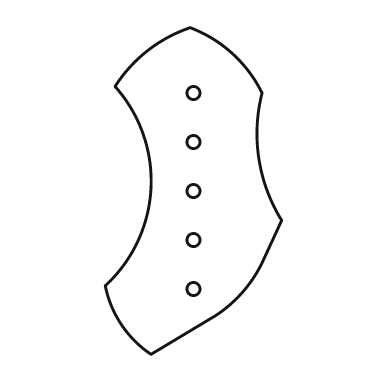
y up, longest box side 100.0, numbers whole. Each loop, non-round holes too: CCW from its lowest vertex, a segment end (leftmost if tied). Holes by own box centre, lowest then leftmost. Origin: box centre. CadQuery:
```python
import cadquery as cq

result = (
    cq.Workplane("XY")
    .moveTo(-13.0, -50.0)
    .lineTo(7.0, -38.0)
    .threePointArc((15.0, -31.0), (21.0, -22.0))
    .lineTo(27.0, -9.0)
    .threePointArc((20.0, 10.0), (21.0, 30.0))
    .threePointArc((12.0, 42.0), (-1.0, 50.0))
    .threePointArc((-14.0, 43.0), (-24.0, 32.0))
    .threePointArc((-13.0, 1.0), (-27.0, -29.0))
    .threePointArc((-22.0, -41.0), (-13.0, -50.0))
    .close()
    .moveTo(0.0, -30.0)
    .circle(2.0)
    .moveTo(0.0, -15.0)
    .circle(2.0)
    .moveTo(0.0, 0.0)
    .circle(2.0)
    .moveTo(0.0, 15.0)
    .circle(2.0)
    .moveTo(0.0, 30.0)
    .circle(2.0)
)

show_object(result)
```